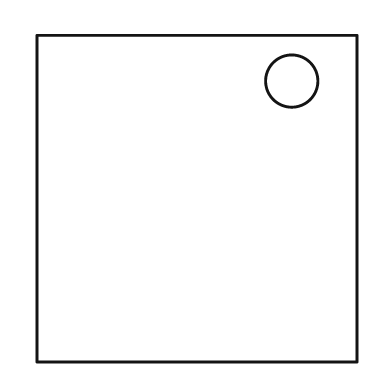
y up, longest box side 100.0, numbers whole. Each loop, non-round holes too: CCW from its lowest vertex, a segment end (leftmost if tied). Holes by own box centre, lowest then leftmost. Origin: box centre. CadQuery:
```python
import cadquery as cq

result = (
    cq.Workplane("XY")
    .moveTo(-49.0, -50.0)
    .lineTo(49.0, -50.0)
    .lineTo(49.0, 50.0)
    .lineTo(-49.0, 50.0)
    .close()
    .moveTo(29.0, 36.0)
    .circle(8.0)
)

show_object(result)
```